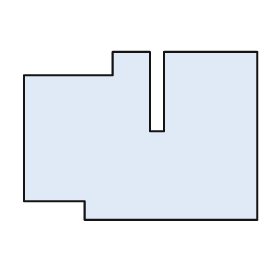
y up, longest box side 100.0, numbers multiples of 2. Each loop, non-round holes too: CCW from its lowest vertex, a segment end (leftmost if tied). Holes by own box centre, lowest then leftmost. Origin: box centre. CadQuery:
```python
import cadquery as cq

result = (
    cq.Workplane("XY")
    .moveTo(-24.0, -36.0)
    .lineTo(50.0, -36.0)
    .lineTo(50.0, 36.0)
    .lineTo(10.0, 36.0)
    .lineTo(10.0, 2.0)
    .lineTo(4.0, 2.0)
    .lineTo(4.0, 36.0)
    .lineTo(-12.0, 36.0)
    .lineTo(-12.0, 26.0)
    .lineTo(-50.0, 26.0)
    .lineTo(-50.0, -28.0)
    .lineTo(-24.0, -28.0)
    .close()
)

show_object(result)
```